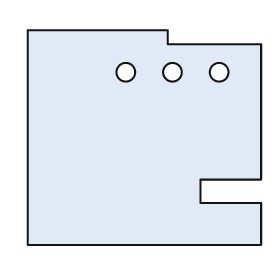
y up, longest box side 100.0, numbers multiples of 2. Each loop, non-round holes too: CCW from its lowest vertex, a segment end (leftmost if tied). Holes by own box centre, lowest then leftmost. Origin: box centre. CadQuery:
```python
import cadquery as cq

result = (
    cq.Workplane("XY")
    .moveTo(-50.0, -46.0)
    .lineTo(50.0, -46.0)
    .lineTo(50.0, -28.0)
    .lineTo(24.0, -28.0)
    .lineTo(24.0, -18.0)
    .lineTo(50.0, -18.0)
    .lineTo(50.0, 40.0)
    .lineTo(10.0, 40.0)
    .lineTo(10.0, 46.0)
    .lineTo(-50.0, 46.0)
    .close()
    .moveTo(-8.0, 28.0)
    .circle(4.0)
    .moveTo(12.0, 28.0)
    .circle(4.0)
    .moveTo(32.0, 28.0)
    .circle(4.0)
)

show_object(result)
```